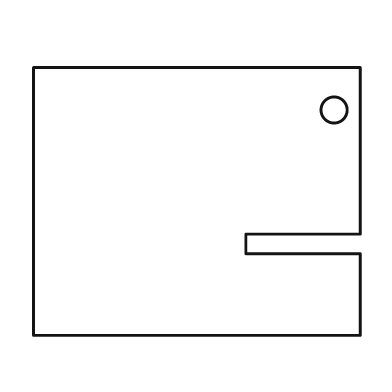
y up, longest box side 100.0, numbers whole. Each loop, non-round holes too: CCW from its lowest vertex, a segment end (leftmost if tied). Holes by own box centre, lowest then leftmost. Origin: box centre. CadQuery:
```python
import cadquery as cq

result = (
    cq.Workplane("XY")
    .moveTo(-50.0, -41.0)
    .lineTo(50.0, -41.0)
    .lineTo(50.0, -16.0)
    .lineTo(15.0, -16.0)
    .lineTo(15.0, -10.0)
    .lineTo(50.0, -10.0)
    .lineTo(50.0, 41.0)
    .lineTo(-50.0, 41.0)
    .close()
    .moveTo(42.0, 28.0)
    .circle(4.0)
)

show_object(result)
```